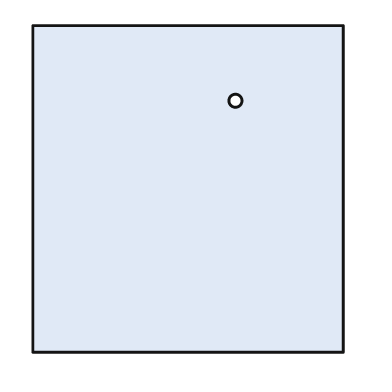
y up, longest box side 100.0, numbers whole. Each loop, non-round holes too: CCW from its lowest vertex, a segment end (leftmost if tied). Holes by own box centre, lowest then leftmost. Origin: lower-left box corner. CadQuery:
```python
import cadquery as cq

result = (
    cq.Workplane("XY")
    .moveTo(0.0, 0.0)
    .lineTo(95.0, 0.0)
    .lineTo(95.0, 100.0)
    .lineTo(0.0, 100.0)
    .close()
    .moveTo(62.0, 77.0)
    .circle(2.0)
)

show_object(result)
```